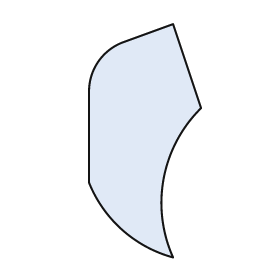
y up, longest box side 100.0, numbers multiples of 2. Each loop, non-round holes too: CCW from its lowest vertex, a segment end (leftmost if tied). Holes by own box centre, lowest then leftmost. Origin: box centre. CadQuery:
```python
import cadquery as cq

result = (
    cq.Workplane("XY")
    .moveTo(12.0, -50.0)
    .threePointArc((8.0, -16.0), (24.0, 14.0))
    .lineTo(12.0, 50.0)
    .lineTo(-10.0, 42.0)
    .threePointArc((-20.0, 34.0), (-24.0, 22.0))
    .lineTo(-24.0, -18.0)
    .threePointArc((-10.0, -38.0), (12.0, -50.0))
    .close()
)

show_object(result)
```